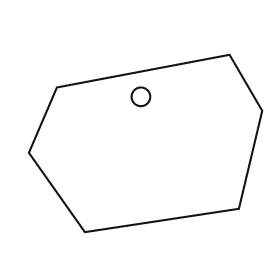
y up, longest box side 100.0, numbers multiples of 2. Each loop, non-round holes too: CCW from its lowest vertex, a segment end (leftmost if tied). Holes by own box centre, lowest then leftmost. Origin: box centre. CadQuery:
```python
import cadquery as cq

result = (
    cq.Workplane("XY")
    .moveTo(-26.0, -38.0)
    .lineTo(40.0, -28.0)
    .lineTo(50.0, 14.0)
    .lineTo(36.0, 38.0)
    .lineTo(-38.0, 24.0)
    .lineTo(-50.0, -4.0)
    .close()
    .moveTo(-2.0, 20.0)
    .circle(4.0)
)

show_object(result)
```